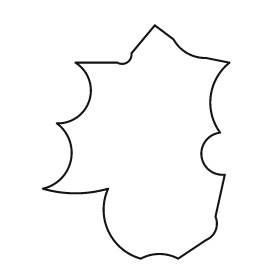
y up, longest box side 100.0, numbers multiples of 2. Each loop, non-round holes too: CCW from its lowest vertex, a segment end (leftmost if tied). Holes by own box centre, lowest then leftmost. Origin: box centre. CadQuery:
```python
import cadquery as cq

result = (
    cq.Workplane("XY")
    .moveTo(2.0, -50.0)
    .threePointArc((10.0, -48.0), (18.0, -50.0))
    .lineTo(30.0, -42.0)
    .threePointArc((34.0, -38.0), (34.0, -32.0))
    .lineTo(38.0, -14.0)
    .threePointArc((28.0, -6.0), (36.0, 4.0))
    .threePointArc((32.0, 20.0), (40.0, 34.0))
    .lineTo(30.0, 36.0)
    .threePointArc((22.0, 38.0), (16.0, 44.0))
    .lineTo(8.0, 50.0)
    .lineTo(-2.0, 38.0)
    .threePointArc((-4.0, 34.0), (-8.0, 34.0))
    .lineTo(-26.0, 34.0)
    .threePointArc((-20.0, 18.0), (-34.0, 8.0))
    .threePointArc((-28.0, -8.0), (-40.0, -20.0))
    .threePointArc((-26.0, -22.0), (-12.0, -20.0))
    .threePointArc((-12.0, -38.0), (2.0, -50.0))
    .close()
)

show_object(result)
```